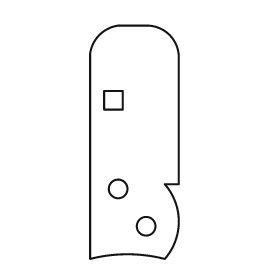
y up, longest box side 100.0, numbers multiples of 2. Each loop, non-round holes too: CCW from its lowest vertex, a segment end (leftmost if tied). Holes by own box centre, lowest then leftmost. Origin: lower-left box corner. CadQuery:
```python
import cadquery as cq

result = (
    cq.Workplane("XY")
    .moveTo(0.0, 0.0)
    .threePointArc((16.0, 2.0), (32.0, 0.0))
    .threePointArc((38.0, 16.0), (32.0, 32.0))
    .lineTo(38.0, 32.0)
    .lineTo(38.0, 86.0)
    .threePointArc((34.0, 96.0), (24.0, 100.0))
    .lineTo(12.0, 100.0)
    .threePointArc((4.0, 96.0), (0.0, 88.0))
    .close()
    .moveTo(24.0, 14.0)
    .circle(4.0)
    .moveTo(12.0, 30.0)
    .circle(4.0)
    .moveTo(6.0, 64.0)
    .lineTo(14.0, 64.0)
    .lineTo(14.0, 72.0)
    .lineTo(6.0, 72.0)
    .close()
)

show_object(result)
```